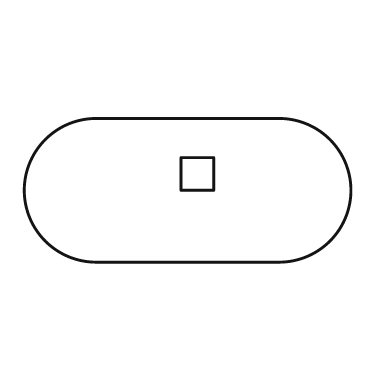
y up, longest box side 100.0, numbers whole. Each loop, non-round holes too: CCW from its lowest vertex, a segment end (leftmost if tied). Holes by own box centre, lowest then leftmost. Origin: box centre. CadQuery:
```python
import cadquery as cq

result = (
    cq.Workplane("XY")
    .moveTo(-28.0, -22.0)
    .lineTo(28.0, -22.0)
    .threePointArc((50.0, 0.0), (28.0, 22.0))
    .lineTo(-28.0, 22.0)
    .threePointArc((-50.0, 0.0), (-28.0, -22.0))
    .close()
    .moveTo(-2.0, 0.0)
    .lineTo(8.0, 0.0)
    .lineTo(8.0, 10.0)
    .lineTo(-2.0, 10.0)
    .close()
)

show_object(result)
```